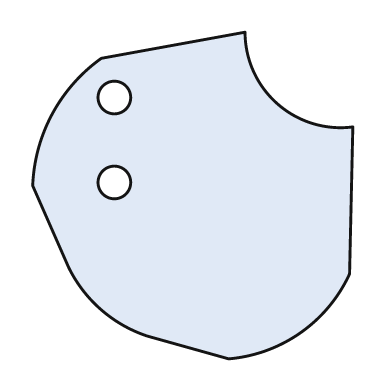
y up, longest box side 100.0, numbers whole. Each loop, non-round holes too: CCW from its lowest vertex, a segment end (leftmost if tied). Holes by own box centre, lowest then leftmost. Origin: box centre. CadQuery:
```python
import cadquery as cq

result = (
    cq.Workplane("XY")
    .moveTo(11.0, -50.0)
    .threePointArc((33.0, -42.0), (48.0, -24.0))
    .lineTo(49.0, 21.0)
    .threePointArc((26.0, 28.0), (16.0, 50.0))
    .lineTo(-28.0, 42.0)
    .threePointArc((-43.0, 25.0), (-49.0, 3.0))
    .lineTo(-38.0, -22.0)
    .threePointArc((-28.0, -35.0), (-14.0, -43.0))
    .close()
    .moveTo(-24.0, 4.0)
    .circle(5.0)
    .moveTo(-24.0, 30.0)
    .circle(5.0)
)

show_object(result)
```